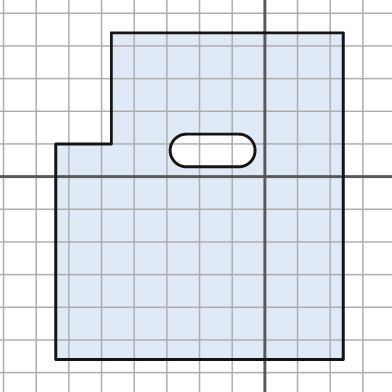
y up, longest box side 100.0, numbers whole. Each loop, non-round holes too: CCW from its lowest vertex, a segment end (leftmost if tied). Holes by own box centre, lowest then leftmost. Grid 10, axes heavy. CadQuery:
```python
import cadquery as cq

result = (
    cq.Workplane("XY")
    .moveTo(-64.0, -56.0)
    .lineTo(24.0, -56.0)
    .lineTo(24.0, 44.0)
    .lineTo(-47.0, 44.0)
    .lineTo(-47.0, 10.0)
    .lineTo(-64.0, 10.0)
    .close()
    .moveTo(-24.0, 3.0)
    .lineTo(-8.0, 3.0)
    .threePointArc((-3.0, 8.0), (-8.0, 13.0))
    .lineTo(-24.0, 13.0)
    .threePointArc((-29.0, 8.0), (-24.0, 3.0))
    .close()
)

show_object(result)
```